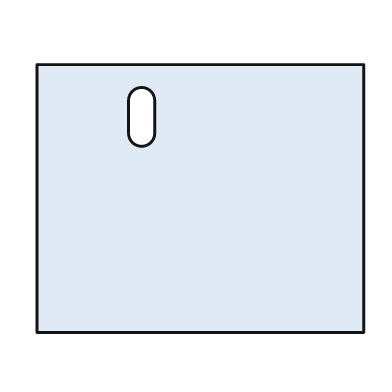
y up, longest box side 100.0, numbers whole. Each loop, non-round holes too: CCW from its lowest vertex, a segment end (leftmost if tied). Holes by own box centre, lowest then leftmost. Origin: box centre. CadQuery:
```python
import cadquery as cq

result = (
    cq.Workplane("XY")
    .moveTo(-50.0, -41.0)
    .lineTo(50.0, -41.0)
    .lineTo(50.0, 41.0)
    .lineTo(-50.0, 41.0)
    .close()
    .moveTo(-22.0, 20.0)
    .threePointArc((-18.0, 16.0), (-14.0, 20.0))
    .lineTo(-14.0, 30.0)
    .threePointArc((-18.0, 34.0), (-22.0, 30.0))
    .close()
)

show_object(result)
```